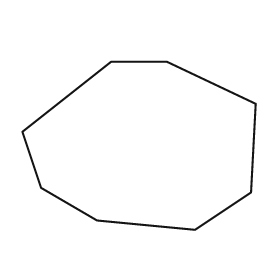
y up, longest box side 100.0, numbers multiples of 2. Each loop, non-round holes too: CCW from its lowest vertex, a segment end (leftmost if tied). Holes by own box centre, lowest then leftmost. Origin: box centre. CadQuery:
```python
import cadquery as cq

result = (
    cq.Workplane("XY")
    .moveTo(24.0, -36.0)
    .lineTo(48.0, -20.0)
    .lineTo(50.0, 18.0)
    .lineTo(12.0, 36.0)
    .lineTo(-12.0, 36.0)
    .lineTo(-50.0, 6.0)
    .lineTo(-42.0, -18.0)
    .lineTo(-18.0, -32.0)
    .close()
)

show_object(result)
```